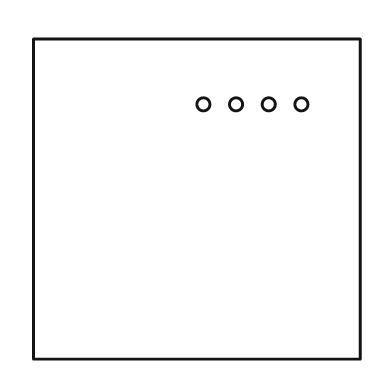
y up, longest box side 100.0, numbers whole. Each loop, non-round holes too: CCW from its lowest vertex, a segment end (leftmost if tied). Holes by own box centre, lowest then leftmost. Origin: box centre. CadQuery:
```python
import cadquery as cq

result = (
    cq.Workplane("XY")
    .moveTo(-50.0, -49.0)
    .lineTo(50.0, -49.0)
    .lineTo(50.0, 49.0)
    .lineTo(-50.0, 49.0)
    .close()
    .moveTo(2.0, 29.0)
    .circle(2.0)
    .moveTo(12.0, 29.0)
    .circle(2.0)
    .moveTo(22.0, 29.0)
    .circle(2.0)
    .moveTo(32.0, 29.0)
    .circle(2.0)
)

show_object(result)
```